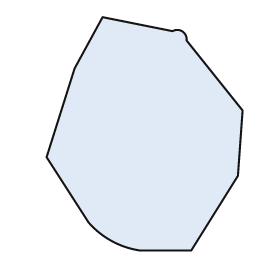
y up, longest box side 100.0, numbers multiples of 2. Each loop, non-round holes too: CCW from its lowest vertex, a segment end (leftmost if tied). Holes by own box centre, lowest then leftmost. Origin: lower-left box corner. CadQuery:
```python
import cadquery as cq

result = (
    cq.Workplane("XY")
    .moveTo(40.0, 0.0)
    .lineTo(62.0, 0.0)
    .lineTo(82.0, 32.0)
    .lineTo(84.0, 60.0)
    .lineTo(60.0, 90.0)
    .threePointArc((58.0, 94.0), (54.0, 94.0))
    .lineTo(24.0, 100.0)
    .lineTo(12.0, 78.0)
    .lineTo(0.0, 40.0)
    .lineTo(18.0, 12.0)
    .threePointArc((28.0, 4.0), (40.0, 0.0))
    .close()
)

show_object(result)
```